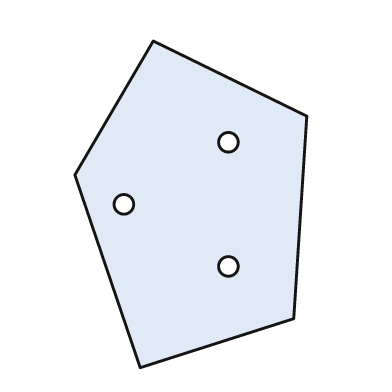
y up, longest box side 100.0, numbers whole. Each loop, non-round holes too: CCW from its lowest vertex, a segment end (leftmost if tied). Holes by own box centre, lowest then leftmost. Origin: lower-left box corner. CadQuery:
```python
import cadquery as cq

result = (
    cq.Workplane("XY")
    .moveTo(20.0, 0.0)
    .lineTo(67.0, 15.0)
    .lineTo(71.0, 77.0)
    .lineTo(24.0, 100.0)
    .lineTo(0.0, 59.0)
    .close()
    .moveTo(47.0, 31.0)
    .circle(3.0)
    .moveTo(15.0, 50.0)
    .circle(3.0)
    .moveTo(47.0, 69.0)
    .circle(3.0)
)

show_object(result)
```